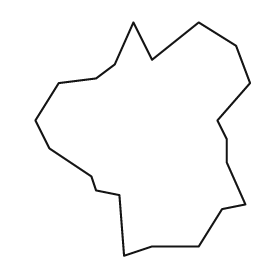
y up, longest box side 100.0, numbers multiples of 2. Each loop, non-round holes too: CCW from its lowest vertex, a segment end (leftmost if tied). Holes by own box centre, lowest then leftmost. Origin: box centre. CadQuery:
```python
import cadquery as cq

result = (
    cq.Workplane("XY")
    .moveTo(-8.0, -50.0)
    .lineTo(4.0, -46.0)
    .lineTo(24.0, -46.0)
    .lineTo(34.0, -30.0)
    .lineTo(44.0, -28.0)
    .lineTo(36.0, -10.0)
    .lineTo(36.0, 0.0)
    .lineTo(32.0, 8.0)
    .lineTo(46.0, 24.0)
    .lineTo(40.0, 40.0)
    .lineTo(24.0, 50.0)
    .lineTo(4.0, 34.0)
    .lineTo(-4.0, 50.0)
    .lineTo(-12.0, 32.0)
    .lineTo(-20.0, 26.0)
    .lineTo(-36.0, 24.0)
    .lineTo(-46.0, 8.0)
    .lineTo(-40.0, -4.0)
    .lineTo(-22.0, -16.0)
    .lineTo(-20.0, -22.0)
    .lineTo(-10.0, -24.0)
    .close()
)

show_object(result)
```